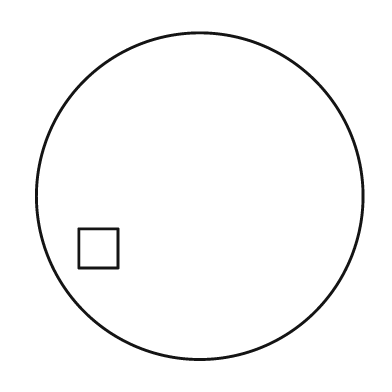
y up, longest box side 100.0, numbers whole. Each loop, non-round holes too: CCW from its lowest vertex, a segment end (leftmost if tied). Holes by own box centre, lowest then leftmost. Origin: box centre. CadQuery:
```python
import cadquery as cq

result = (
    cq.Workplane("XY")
    .moveTo(0.0, 0.0)
    .circle(50.0)
    .moveTo(-37.0, -22.0)
    .lineTo(-25.0, -22.0)
    .lineTo(-25.0, -10.0)
    .lineTo(-37.0, -10.0)
    .close()
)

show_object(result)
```